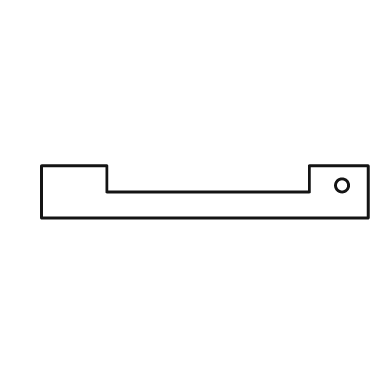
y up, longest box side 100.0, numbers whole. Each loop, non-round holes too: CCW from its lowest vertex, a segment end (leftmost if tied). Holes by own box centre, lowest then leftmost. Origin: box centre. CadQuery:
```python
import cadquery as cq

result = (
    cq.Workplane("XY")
    .moveTo(-50.0, -8.0)
    .lineTo(50.0, -8.0)
    .lineTo(50.0, 8.0)
    .lineTo(32.0, 8.0)
    .lineTo(32.0, 0.0)
    .lineTo(-30.0, 0.0)
    .lineTo(-30.0, 8.0)
    .lineTo(-50.0, 8.0)
    .close()
    .moveTo(42.0, 2.0)
    .circle(2.0)
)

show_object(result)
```